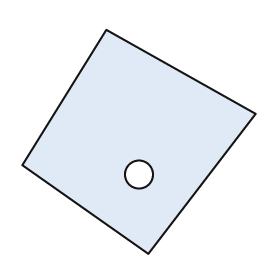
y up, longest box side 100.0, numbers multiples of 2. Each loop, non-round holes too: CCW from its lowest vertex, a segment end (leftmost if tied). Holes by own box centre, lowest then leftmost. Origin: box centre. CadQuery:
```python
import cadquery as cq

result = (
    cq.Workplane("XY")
    .moveTo(4.0, -48.0)
    .lineTo(50.0, 12.0)
    .lineTo(-14.0, 48.0)
    .lineTo(-50.0, -10.0)
    .close()
    .moveTo(0.0, -14.0)
    .circle(6.0)
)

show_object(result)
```